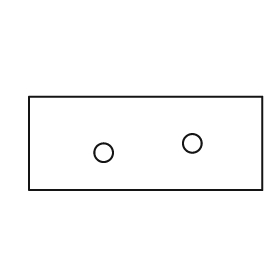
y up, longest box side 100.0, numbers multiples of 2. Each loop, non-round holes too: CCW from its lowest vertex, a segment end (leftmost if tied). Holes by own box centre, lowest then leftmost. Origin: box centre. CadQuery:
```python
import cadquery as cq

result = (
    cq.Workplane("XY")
    .moveTo(-50.0, -20.0)
    .lineTo(50.0, -20.0)
    .lineTo(50.0, 20.0)
    .lineTo(-50.0, 20.0)
    .close()
    .moveTo(-18.0, -4.0)
    .circle(4.0)
    .moveTo(20.0, 0.0)
    .circle(4.0)
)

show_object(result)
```